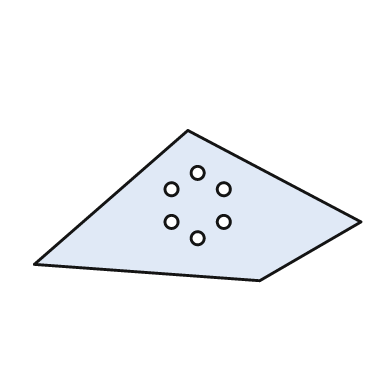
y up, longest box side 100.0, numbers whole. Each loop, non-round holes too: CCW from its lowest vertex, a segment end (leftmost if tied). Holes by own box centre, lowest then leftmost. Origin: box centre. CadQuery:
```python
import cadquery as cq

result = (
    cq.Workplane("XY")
    .moveTo(19.0, -23.0)
    .lineTo(50.0, -5.0)
    .lineTo(-3.0, 23.0)
    .lineTo(-50.0, -18.0)
    .close()
    .moveTo(0.0, -10.0)
    .circle(2.0)
    .moveTo(-8.0, -5.0)
    .circle(2.0)
    .moveTo(8.0, -5.0)
    .circle(2.0)
    .moveTo(-8.0, 5.0)
    .circle(2.0)
    .moveTo(8.0, 5.0)
    .circle(2.0)
    .moveTo(0.0, 10.0)
    .circle(2.0)
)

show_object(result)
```